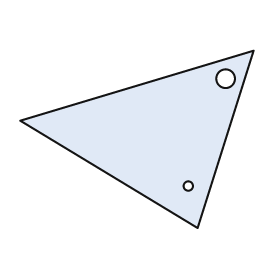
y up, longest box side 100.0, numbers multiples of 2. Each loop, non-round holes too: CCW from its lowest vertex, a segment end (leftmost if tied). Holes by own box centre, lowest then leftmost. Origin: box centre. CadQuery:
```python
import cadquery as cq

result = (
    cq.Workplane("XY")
    .moveTo(26.0, -38.0)
    .lineTo(50.0, 38.0)
    .lineTo(-50.0, 8.0)
    .close()
    .moveTo(22.0, -20.0)
    .circle(2.0)
    .moveTo(38.0, 26.0)
    .circle(4.0)
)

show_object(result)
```